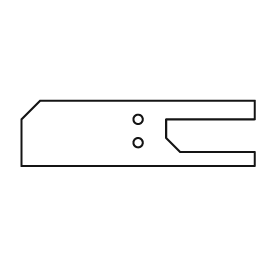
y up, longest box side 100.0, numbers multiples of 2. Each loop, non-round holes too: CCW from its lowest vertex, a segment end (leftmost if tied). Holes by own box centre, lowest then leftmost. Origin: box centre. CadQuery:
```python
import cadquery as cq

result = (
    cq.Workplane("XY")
    .moveTo(-50.0, -14.0)
    .lineTo(50.0, -14.0)
    .lineTo(50.0, -8.0)
    .lineTo(18.0, -8.0)
    .lineTo(12.0, -2.0)
    .lineTo(12.0, 6.0)
    .lineTo(50.0, 6.0)
    .lineTo(50.0, 14.0)
    .lineTo(-42.0, 14.0)
    .lineTo(-50.0, 6.0)
    .close()
    .moveTo(0.0, -4.0)
    .circle(2.0)
    .moveTo(0.0, 6.0)
    .circle(2.0)
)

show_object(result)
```